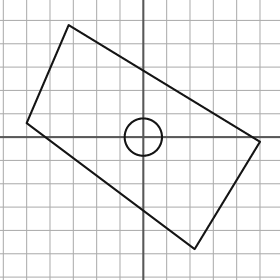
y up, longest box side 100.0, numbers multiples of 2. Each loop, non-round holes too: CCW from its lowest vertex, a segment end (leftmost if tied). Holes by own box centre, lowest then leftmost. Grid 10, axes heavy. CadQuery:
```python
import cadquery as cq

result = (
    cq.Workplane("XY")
    .moveTo(22.0, -48.0)
    .lineTo(50.0, -2.0)
    .lineTo(-32.0, 48.0)
    .lineTo(-50.0, 6.0)
    .close()
    .moveTo(0.0, 0.0)
    .circle(8.0)
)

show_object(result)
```